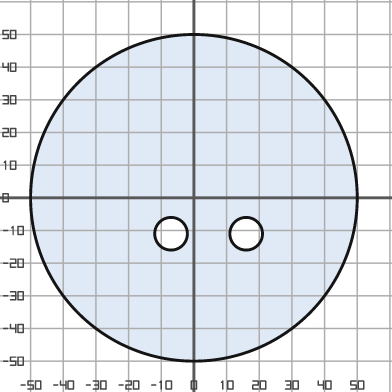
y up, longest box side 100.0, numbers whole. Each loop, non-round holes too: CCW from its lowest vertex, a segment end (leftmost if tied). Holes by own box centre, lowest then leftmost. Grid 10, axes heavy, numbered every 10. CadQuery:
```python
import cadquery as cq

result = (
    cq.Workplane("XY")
    .moveTo(0.0, 0.0)
    .circle(50.0)
    .moveTo(-7.0, -11.0)
    .circle(5.0)
    .moveTo(16.0, -11.0)
    .circle(5.0)
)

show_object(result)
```